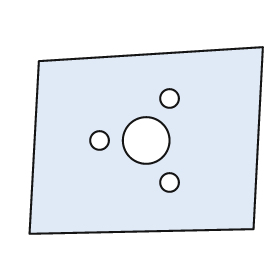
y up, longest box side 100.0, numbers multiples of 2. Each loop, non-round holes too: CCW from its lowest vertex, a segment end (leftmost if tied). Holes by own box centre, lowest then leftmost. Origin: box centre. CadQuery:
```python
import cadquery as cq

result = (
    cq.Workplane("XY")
    .moveTo(-50.0, -40.0)
    .lineTo(46.0, -38.0)
    .lineTo(50.0, 40.0)
    .lineTo(-46.0, 34.0)
    .close()
    .moveTo(10.0, -18.0)
    .circle(4.0)
    .moveTo(-20.0, 0.0)
    .circle(4.0)
    .moveTo(0.0, 0.0)
    .circle(10.0)
    .moveTo(10.0, 18.0)
    .circle(4.0)
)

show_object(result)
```